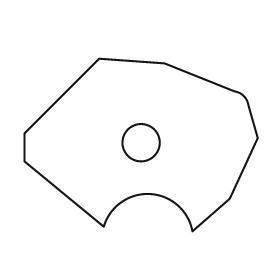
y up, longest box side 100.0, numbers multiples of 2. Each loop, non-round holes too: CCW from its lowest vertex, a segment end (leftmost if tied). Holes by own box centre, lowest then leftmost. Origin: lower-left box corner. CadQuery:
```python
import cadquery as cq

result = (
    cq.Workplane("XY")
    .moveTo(72.0, 0.0)
    .lineTo(88.0, 14.0)
    .lineTo(100.0, 40.0)
    .lineTo(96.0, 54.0)
    .threePointArc((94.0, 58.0), (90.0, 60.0))
    .lineTo(60.0, 72.0)
    .lineTo(32.0, 74.0)
    .lineTo(0.0, 42.0)
    .lineTo(0.0, 30.0)
    .lineTo(34.0, 2.0)
    .threePointArc((54.0, 16.0), (72.0, 0.0))
    .close()
    .moveTo(50.0, 38.0)
    .circle(8.0)
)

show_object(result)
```